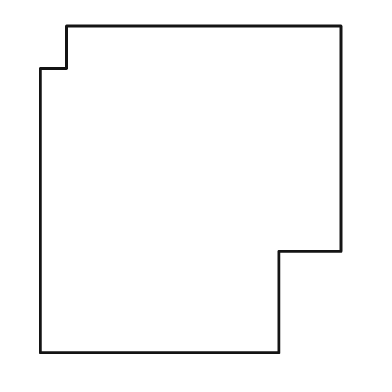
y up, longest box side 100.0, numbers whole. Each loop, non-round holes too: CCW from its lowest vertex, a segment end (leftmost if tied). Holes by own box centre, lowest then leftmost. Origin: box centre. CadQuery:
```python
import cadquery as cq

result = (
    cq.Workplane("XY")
    .moveTo(-46.0, -50.0)
    .lineTo(27.0, -50.0)
    .lineTo(27.0, -19.0)
    .lineTo(46.0, -19.0)
    .lineTo(46.0, 50.0)
    .lineTo(-38.0, 50.0)
    .lineTo(-38.0, 37.0)
    .lineTo(-46.0, 37.0)
    .close()
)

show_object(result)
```